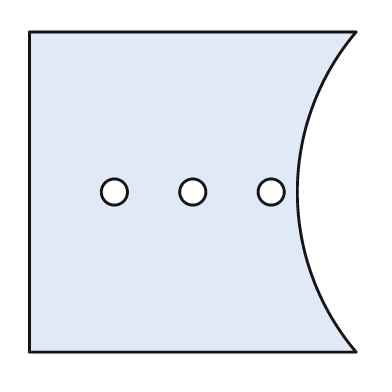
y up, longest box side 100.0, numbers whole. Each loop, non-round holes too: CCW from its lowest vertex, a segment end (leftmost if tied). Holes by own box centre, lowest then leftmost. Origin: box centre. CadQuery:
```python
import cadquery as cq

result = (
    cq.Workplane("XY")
    .moveTo(-50.0, -49.0)
    .lineTo(50.0, -49.0)
    .threePointArc((32.0, 0.0), (50.0, 49.0))
    .lineTo(-50.0, 49.0)
    .close()
    .moveTo(-24.0, 0.0)
    .circle(4.0)
    .moveTo(0.0, 0.0)
    .circle(4.0)
    .moveTo(24.0, 0.0)
    .circle(4.0)
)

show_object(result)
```